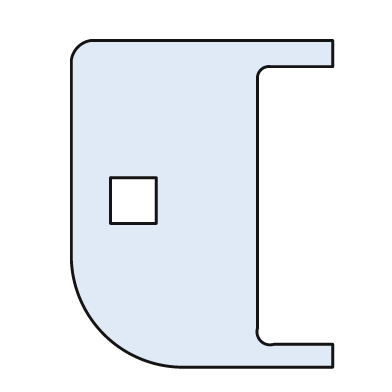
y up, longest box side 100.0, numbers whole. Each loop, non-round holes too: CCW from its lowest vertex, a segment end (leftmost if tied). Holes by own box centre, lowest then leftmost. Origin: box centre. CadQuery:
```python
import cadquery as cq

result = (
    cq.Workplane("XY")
    .moveTo(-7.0, -50.0)
    .lineTo(40.0, -50.0)
    .lineTo(40.0, -43.0)
    .lineTo(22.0, -43.0)
    .threePointArc((18.0, -42.0), (17.0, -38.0))
    .lineTo(17.0, 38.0)
    .threePointArc((18.0, 41.0), (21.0, 42.0))
    .lineTo(40.0, 42.0)
    .lineTo(40.0, 50.0)
    .lineTo(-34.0, 50.0)
    .threePointArc((-38.0, 48.0), (-40.0, 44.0))
    .lineTo(-40.0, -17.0)
    .threePointArc((-30.0, -40.0), (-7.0, -50.0))
    .close()
    .moveTo(-28.0, -6.0)
    .lineTo(-14.0, -6.0)
    .lineTo(-14.0, 8.0)
    .lineTo(-28.0, 8.0)
    .close()
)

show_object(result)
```